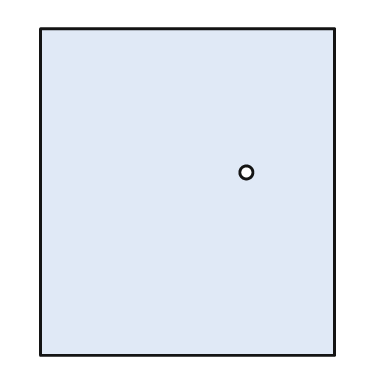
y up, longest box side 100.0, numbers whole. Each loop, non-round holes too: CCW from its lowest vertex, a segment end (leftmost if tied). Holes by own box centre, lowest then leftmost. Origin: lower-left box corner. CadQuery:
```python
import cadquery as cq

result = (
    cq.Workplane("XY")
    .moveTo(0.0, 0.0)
    .lineTo(90.0, 0.0)
    .lineTo(90.0, 100.0)
    .lineTo(0.0, 100.0)
    .close()
    .moveTo(63.0, 56.0)
    .circle(2.0)
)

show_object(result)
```